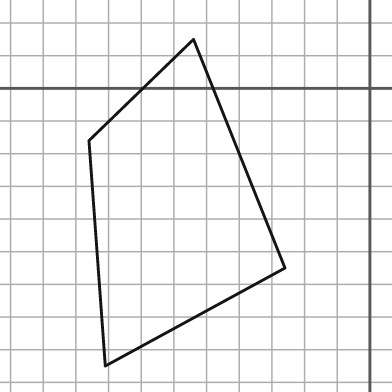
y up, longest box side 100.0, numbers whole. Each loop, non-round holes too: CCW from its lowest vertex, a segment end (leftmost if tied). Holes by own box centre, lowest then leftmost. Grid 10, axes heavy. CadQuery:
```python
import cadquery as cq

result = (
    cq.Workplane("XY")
    .moveTo(-81.0, -85.0)
    .lineTo(-26.0, -55.0)
    .lineTo(-54.0, 15.0)
    .lineTo(-86.0, -16.0)
    .close()
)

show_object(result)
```